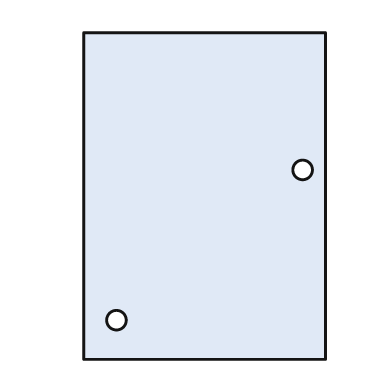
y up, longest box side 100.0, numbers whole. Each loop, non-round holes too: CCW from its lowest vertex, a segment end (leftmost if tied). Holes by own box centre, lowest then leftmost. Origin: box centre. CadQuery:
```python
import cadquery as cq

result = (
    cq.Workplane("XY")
    .moveTo(-37.0, -50.0)
    .lineTo(37.0, -50.0)
    .lineTo(37.0, 50.0)
    .lineTo(-37.0, 50.0)
    .close()
    .moveTo(-27.0, -38.0)
    .circle(3.0)
    .moveTo(30.0, 8.0)
    .circle(3.0)
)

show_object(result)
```